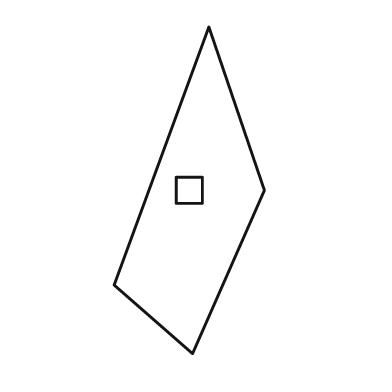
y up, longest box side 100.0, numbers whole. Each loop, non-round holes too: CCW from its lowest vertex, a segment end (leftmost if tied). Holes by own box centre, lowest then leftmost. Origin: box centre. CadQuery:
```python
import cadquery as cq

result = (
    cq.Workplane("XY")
    .moveTo(1.0, -50.0)
    .lineTo(23.0, 0.0)
    .lineTo(6.0, 50.0)
    .lineTo(-23.0, -29.0)
    .close()
    .moveTo(-4.0, -4.0)
    .lineTo(4.0, -4.0)
    .lineTo(4.0, 4.0)
    .lineTo(-4.0, 4.0)
    .close()
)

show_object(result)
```